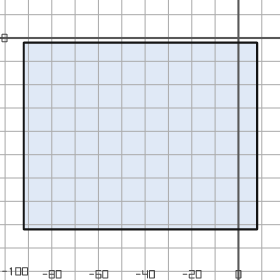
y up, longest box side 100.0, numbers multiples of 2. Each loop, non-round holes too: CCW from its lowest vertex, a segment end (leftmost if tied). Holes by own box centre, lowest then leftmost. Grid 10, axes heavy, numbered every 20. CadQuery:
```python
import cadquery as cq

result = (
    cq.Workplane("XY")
    .moveTo(-92.0, -82.0)
    .lineTo(8.0, -82.0)
    .lineTo(8.0, -2.0)
    .lineTo(-92.0, -2.0)
    .close()
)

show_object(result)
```